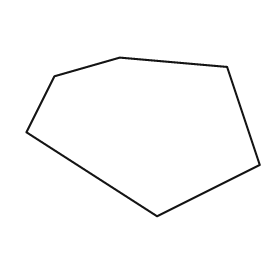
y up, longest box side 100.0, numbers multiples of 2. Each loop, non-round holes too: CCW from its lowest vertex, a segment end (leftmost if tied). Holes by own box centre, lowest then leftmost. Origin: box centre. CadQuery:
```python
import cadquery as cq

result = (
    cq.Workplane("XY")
    .moveTo(6.0, -34.0)
    .lineTo(50.0, -12.0)
    .lineTo(36.0, 30.0)
    .lineTo(-10.0, 34.0)
    .lineTo(-38.0, 26.0)
    .lineTo(-50.0, 2.0)
    .close()
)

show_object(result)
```